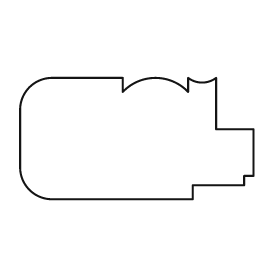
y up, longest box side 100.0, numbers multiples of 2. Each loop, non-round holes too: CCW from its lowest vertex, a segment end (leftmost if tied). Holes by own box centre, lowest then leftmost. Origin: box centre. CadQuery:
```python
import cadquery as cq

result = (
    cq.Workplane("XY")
    .moveTo(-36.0, -26.0)
    .lineTo(24.0, -26.0)
    .lineTo(24.0, -20.0)
    .lineTo(46.0, -20.0)
    .lineTo(46.0, -16.0)
    .lineTo(50.0, -16.0)
    .lineTo(50.0, 4.0)
    .lineTo(34.0, 4.0)
    .lineTo(34.0, 26.0)
    .threePointArc((28.0, 24.0), (22.0, 26.0))
    .lineTo(22.0, 20.0)
    .threePointArc((8.0, 26.0), (-6.0, 20.0))
    .lineTo(-6.0, 26.0)
    .lineTo(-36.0, 26.0)
    .threePointArc((-46.0, 22.0), (-50.0, 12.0))
    .lineTo(-50.0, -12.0)
    .threePointArc((-46.0, -22.0), (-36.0, -26.0))
    .close()
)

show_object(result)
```